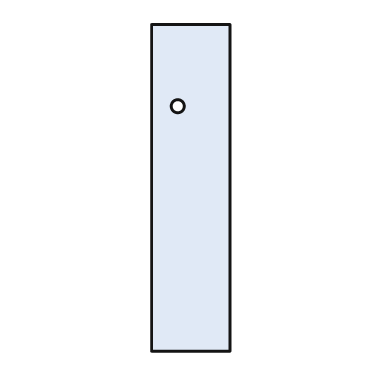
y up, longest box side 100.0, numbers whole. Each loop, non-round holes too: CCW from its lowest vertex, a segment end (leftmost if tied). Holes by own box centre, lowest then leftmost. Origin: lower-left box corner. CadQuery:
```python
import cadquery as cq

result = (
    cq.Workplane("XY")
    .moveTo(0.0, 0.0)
    .lineTo(24.0, 0.0)
    .lineTo(24.0, 100.0)
    .lineTo(0.0, 100.0)
    .close()
    .moveTo(8.0, 75.0)
    .circle(2.0)
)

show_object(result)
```